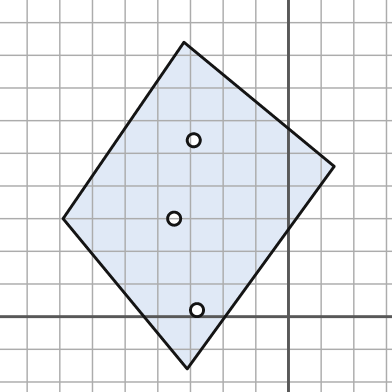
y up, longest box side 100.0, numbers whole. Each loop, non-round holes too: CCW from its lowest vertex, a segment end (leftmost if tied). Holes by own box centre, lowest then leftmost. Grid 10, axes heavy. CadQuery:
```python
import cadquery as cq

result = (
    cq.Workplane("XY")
    .moveTo(-31.0, -16.0)
    .lineTo(14.0, 46.0)
    .lineTo(-32.0, 84.0)
    .lineTo(-69.0, 30.0)
    .close()
    .moveTo(-28.0, 2.0)
    .circle(2.0)
    .moveTo(-35.0, 30.0)
    .circle(2.0)
    .moveTo(-29.0, 54.0)
    .circle(2.0)
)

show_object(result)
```